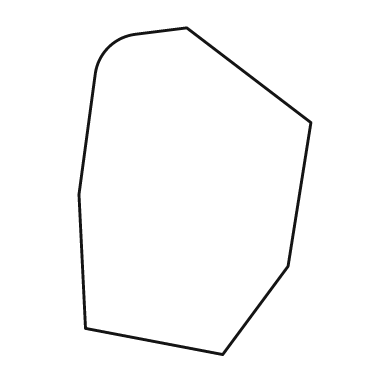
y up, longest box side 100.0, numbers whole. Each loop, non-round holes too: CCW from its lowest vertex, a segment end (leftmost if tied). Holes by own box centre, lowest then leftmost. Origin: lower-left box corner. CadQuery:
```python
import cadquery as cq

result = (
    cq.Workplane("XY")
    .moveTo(44.0, 0.0)
    .lineTo(64.0, 27.0)
    .lineTo(71.0, 71.0)
    .lineTo(33.0, 100.0)
    .lineTo(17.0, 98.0)
    .threePointArc((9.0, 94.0), (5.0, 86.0))
    .lineTo(0.0, 49.0)
    .lineTo(2.0, 8.0)
    .close()
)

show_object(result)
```